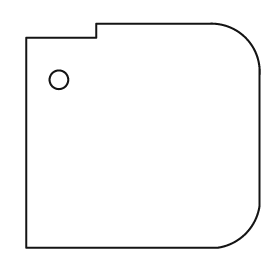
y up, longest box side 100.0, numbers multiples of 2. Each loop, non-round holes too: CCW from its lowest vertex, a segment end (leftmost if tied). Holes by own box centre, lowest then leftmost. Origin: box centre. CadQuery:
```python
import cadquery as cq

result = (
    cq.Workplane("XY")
    .moveTo(-50.0, -48.0)
    .lineTo(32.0, -48.0)
    .threePointArc((44.0, -42.0), (50.0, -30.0))
    .lineTo(50.0, 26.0)
    .threePointArc((44.0, 42.0), (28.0, 48.0))
    .lineTo(-20.0, 48.0)
    .lineTo(-20.0, 42.0)
    .lineTo(-50.0, 42.0)
    .close()
    .moveTo(-36.0, 24.0)
    .circle(4.0)
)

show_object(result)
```